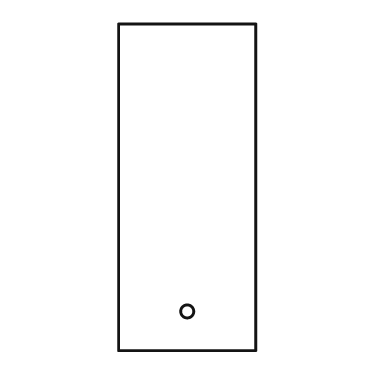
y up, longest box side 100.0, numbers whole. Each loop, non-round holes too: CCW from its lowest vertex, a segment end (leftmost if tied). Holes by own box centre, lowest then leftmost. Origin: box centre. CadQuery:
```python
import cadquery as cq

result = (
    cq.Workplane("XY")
    .moveTo(-21.0, -50.0)
    .lineTo(21.0, -50.0)
    .lineTo(21.0, 50.0)
    .lineTo(-21.0, 50.0)
    .close()
    .moveTo(0.0, -38.0)
    .circle(2.0)
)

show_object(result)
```